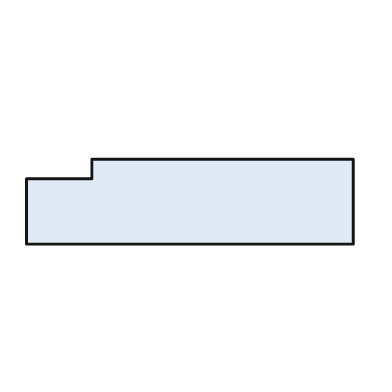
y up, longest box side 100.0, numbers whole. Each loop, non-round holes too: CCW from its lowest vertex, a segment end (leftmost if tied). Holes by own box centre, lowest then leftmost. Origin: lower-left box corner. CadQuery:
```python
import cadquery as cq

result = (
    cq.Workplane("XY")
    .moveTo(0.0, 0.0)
    .lineTo(100.0, 0.0)
    .lineTo(100.0, 26.0)
    .lineTo(20.0, 26.0)
    .lineTo(20.0, 20.0)
    .lineTo(0.0, 20.0)
    .close()
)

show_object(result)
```